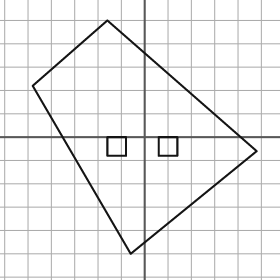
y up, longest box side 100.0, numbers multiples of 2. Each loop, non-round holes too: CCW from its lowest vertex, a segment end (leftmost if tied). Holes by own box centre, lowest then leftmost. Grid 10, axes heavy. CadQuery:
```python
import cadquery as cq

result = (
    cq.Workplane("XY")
    .moveTo(-6.0, -50.0)
    .lineTo(48.0, -6.0)
    .lineTo(-16.0, 50.0)
    .lineTo(-48.0, 22.0)
    .close()
    .moveTo(-16.0, -8.0)
    .lineTo(-8.0, -8.0)
    .lineTo(-8.0, 0.0)
    .lineTo(-16.0, 0.0)
    .close()
    .moveTo(6.0, -8.0)
    .lineTo(14.0, -8.0)
    .lineTo(14.0, 0.0)
    .lineTo(6.0, 0.0)
    .close()
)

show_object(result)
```